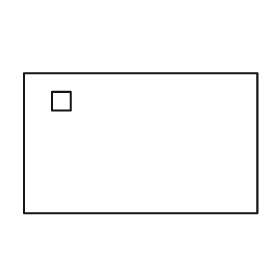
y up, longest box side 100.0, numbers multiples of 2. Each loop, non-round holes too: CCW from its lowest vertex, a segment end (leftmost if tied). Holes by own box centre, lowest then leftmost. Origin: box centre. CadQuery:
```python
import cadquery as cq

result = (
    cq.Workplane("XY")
    .moveTo(-50.0, -30.0)
    .lineTo(50.0, -30.0)
    .lineTo(50.0, 30.0)
    .lineTo(-50.0, 30.0)
    .close()
    .moveTo(-38.0, 14.0)
    .lineTo(-30.0, 14.0)
    .lineTo(-30.0, 22.0)
    .lineTo(-38.0, 22.0)
    .close()
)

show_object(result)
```